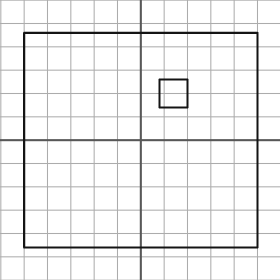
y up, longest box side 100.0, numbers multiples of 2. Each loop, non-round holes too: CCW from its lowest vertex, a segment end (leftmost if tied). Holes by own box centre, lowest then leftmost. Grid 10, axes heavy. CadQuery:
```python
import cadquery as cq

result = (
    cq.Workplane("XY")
    .moveTo(-50.0, -46.0)
    .lineTo(50.0, -46.0)
    .lineTo(50.0, 46.0)
    .lineTo(-50.0, 46.0)
    .close()
    .moveTo(8.0, 14.0)
    .lineTo(20.0, 14.0)
    .lineTo(20.0, 26.0)
    .lineTo(8.0, 26.0)
    .close()
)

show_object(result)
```